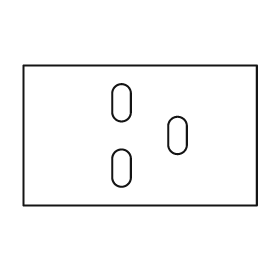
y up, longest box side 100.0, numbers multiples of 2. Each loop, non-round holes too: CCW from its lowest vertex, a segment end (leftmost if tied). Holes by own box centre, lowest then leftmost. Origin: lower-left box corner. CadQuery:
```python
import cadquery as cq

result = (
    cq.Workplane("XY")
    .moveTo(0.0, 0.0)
    .lineTo(100.0, 0.0)
    .lineTo(100.0, 60.0)
    .lineTo(0.0, 60.0)
    .close()
    .moveTo(38.0, 12.0)
    .threePointArc((42.0, 8.0), (46.0, 12.0))
    .lineTo(46.0, 20.0)
    .threePointArc((42.0, 24.0), (38.0, 20.0))
    .close()
    .moveTo(62.0, 26.0)
    .threePointArc((66.0, 22.0), (70.0, 26.0))
    .lineTo(70.0, 34.0)
    .threePointArc((66.0, 38.0), (62.0, 34.0))
    .close()
    .moveTo(38.0, 40.0)
    .threePointArc((42.0, 36.0), (46.0, 40.0))
    .lineTo(46.0, 48.0)
    .threePointArc((42.0, 52.0), (38.0, 48.0))
    .close()
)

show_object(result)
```